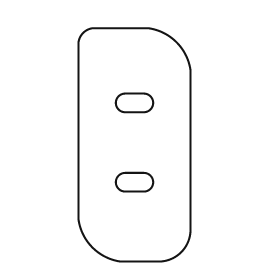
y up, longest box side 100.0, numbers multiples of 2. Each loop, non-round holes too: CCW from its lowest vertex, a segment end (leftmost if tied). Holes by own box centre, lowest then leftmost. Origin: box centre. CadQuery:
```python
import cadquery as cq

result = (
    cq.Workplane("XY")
    .moveTo(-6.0, -50.0)
    .lineTo(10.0, -50.0)
    .threePointArc((20.0, -46.0), (24.0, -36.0))
    .lineTo(24.0, 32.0)
    .threePointArc((18.0, 44.0), (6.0, 50.0))
    .lineTo(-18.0, 50.0)
    .threePointArc((-22.0, 48.0), (-24.0, 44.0))
    .lineTo(-24.0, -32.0)
    .threePointArc((-18.0, -44.0), (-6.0, -50.0))
    .close()
    .moveTo(-4.0, -20.0)
    .lineTo(4.0, -20.0)
    .threePointArc((8.0, -16.0), (4.0, -12.0))
    .lineTo(-4.0, -12.0)
    .threePointArc((-8.0, -16.0), (-4.0, -20.0))
    .close()
    .moveTo(-4.0, 14.0)
    .lineTo(4.0, 14.0)
    .threePointArc((8.0, 18.0), (4.0, 22.0))
    .lineTo(-4.0, 22.0)
    .threePointArc((-8.0, 18.0), (-4.0, 14.0))
    .close()
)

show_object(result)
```